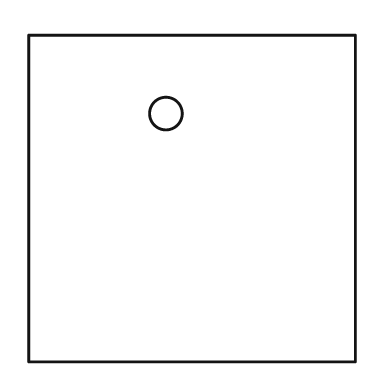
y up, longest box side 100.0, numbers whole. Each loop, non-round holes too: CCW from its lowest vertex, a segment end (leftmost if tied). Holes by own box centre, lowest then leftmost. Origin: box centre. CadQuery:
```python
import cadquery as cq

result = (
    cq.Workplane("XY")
    .moveTo(-50.0, -50.0)
    .lineTo(50.0, -50.0)
    .lineTo(50.0, 50.0)
    .lineTo(-50.0, 50.0)
    .close()
    .moveTo(-8.0, 26.0)
    .circle(5.0)
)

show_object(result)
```